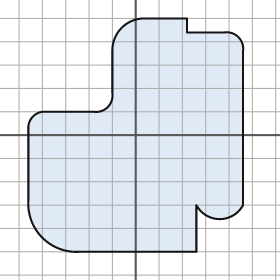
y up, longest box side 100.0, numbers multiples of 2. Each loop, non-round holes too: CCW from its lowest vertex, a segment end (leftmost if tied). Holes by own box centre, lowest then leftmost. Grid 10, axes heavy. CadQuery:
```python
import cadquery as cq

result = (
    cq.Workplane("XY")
    .moveTo(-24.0, -50.0)
    .lineTo(26.0, -50.0)
    .lineTo(26.0, -30.0)
    .threePointArc((36.0, -36.0), (46.0, -30.0))
    .lineTo(46.0, 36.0)
    .threePointArc((44.0, 42.0), (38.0, 44.0))
    .lineTo(22.0, 44.0)
    .lineTo(22.0, 50.0)
    .lineTo(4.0, 50.0)
    .threePointArc((-6.0, 46.0), (-10.0, 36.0))
    .lineTo(-10.0, 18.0)
    .threePointArc((-12.0, 12.0), (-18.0, 10.0))
    .lineTo(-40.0, 10.0)
    .threePointArc((-44.0, 8.0), (-46.0, 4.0))
    .lineTo(-46.0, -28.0)
    .threePointArc((-40.0, -44.0), (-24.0, -50.0))
    .close()
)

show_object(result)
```